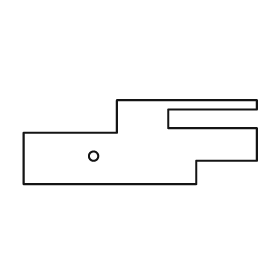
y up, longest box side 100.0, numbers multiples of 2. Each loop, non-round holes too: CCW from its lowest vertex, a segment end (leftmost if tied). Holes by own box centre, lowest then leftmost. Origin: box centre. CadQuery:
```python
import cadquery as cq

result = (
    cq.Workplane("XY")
    .moveTo(-50.0, -18.0)
    .lineTo(24.0, -18.0)
    .lineTo(24.0, -8.0)
    .lineTo(50.0, -8.0)
    .lineTo(50.0, 6.0)
    .lineTo(12.0, 6.0)
    .lineTo(12.0, 14.0)
    .lineTo(50.0, 14.0)
    .lineTo(50.0, 18.0)
    .lineTo(-10.0, 18.0)
    .lineTo(-10.0, 4.0)
    .lineTo(-50.0, 4.0)
    .close()
    .moveTo(-20.0, -6.0)
    .circle(2.0)
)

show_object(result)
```